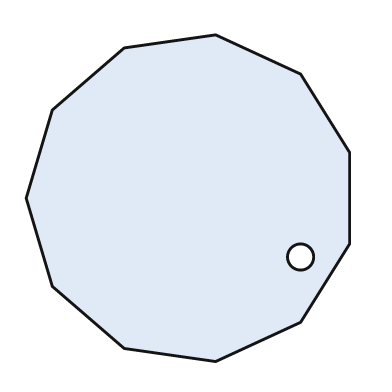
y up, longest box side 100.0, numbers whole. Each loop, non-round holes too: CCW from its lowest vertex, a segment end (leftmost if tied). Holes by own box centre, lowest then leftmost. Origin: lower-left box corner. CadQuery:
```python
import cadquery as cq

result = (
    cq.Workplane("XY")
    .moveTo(58.0, 0.0)
    .lineTo(84.0, 12.0)
    .lineTo(99.0, 36.0)
    .lineTo(99.0, 64.0)
    .lineTo(84.0, 88.0)
    .lineTo(58.0, 100.0)
    .lineTo(30.0, 96.0)
    .lineTo(8.0, 77.0)
    .lineTo(0.0, 50.0)
    .lineTo(8.0, 23.0)
    .lineTo(30.0, 4.0)
    .close()
    .moveTo(84.0, 32.0)
    .circle(4.0)
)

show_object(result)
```